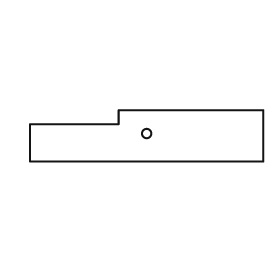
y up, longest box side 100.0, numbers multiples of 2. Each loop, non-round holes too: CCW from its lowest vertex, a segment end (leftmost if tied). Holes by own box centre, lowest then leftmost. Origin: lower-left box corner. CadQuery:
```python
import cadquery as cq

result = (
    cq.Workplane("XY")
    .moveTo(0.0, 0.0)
    .lineTo(100.0, 0.0)
    .lineTo(100.0, 22.0)
    .lineTo(38.0, 22.0)
    .lineTo(38.0, 16.0)
    .lineTo(0.0, 16.0)
    .close()
    .moveTo(50.0, 12.0)
    .circle(2.0)
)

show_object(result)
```